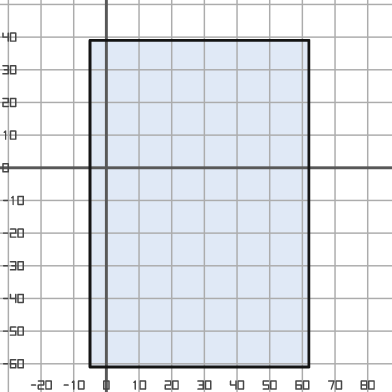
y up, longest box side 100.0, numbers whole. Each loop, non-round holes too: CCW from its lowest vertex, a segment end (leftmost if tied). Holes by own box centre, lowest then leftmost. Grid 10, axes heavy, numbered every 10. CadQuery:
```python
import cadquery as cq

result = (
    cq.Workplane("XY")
    .moveTo(-5.0, -61.0)
    .lineTo(62.0, -61.0)
    .lineTo(62.0, 39.0)
    .lineTo(-5.0, 39.0)
    .close()
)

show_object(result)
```